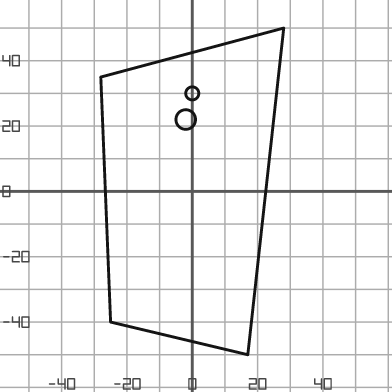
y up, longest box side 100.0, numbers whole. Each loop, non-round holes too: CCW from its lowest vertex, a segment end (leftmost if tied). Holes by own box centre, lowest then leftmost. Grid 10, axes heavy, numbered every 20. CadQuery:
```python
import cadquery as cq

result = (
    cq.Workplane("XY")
    .moveTo(17.0, -50.0)
    .lineTo(28.0, 50.0)
    .lineTo(-28.0, 35.0)
    .lineTo(-25.0, -40.0)
    .close()
    .moveTo(-2.0, 22.0)
    .circle(3.0)
    .moveTo(0.0, 30.0)
    .circle(2.0)
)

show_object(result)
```